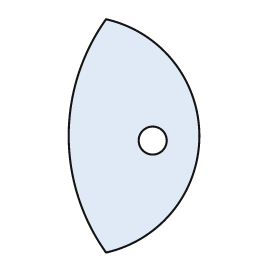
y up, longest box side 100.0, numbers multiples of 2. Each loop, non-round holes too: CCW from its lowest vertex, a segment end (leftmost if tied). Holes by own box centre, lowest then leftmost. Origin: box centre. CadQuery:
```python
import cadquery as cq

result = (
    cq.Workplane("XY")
    .moveTo(-12.0, -50.0)
    .threePointArc((28.0, 0.0), (-12.0, 50.0))
    .threePointArc((-28.0, 0.0), (-12.0, -50.0))
    .close()
    .moveTo(8.0, -2.0)
    .circle(6.0)
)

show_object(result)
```